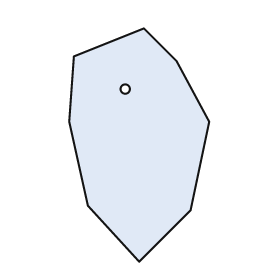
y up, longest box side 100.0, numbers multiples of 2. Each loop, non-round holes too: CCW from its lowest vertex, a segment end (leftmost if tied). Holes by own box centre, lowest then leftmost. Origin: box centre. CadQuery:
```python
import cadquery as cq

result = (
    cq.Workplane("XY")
    .moveTo(0.0, -50.0)
    .lineTo(22.0, -28.0)
    .lineTo(30.0, 10.0)
    .lineTo(16.0, 36.0)
    .lineTo(2.0, 50.0)
    .lineTo(-28.0, 38.0)
    .lineTo(-30.0, 10.0)
    .lineTo(-22.0, -26.0)
    .close()
    .moveTo(-6.0, 24.0)
    .circle(2.0)
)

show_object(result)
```